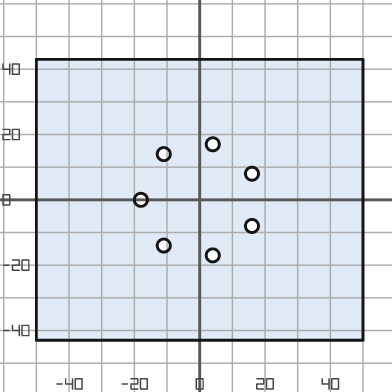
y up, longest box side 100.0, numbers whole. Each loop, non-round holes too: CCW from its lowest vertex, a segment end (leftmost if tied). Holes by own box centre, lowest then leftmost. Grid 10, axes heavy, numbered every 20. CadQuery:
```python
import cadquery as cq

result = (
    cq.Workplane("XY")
    .moveTo(-50.0, -43.0)
    .lineTo(50.0, -43.0)
    .lineTo(50.0, 43.0)
    .lineTo(-50.0, 43.0)
    .close()
    .moveTo(4.0, -17.0)
    .circle(2.0)
    .moveTo(-11.0, -14.0)
    .circle(2.0)
    .moveTo(16.0, -8.0)
    .circle(2.0)
    .moveTo(-18.0, 0.0)
    .circle(2.0)
    .moveTo(16.0, 8.0)
    .circle(2.0)
    .moveTo(-11.0, 14.0)
    .circle(2.0)
    .moveTo(4.0, 17.0)
    .circle(2.0)
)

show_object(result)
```